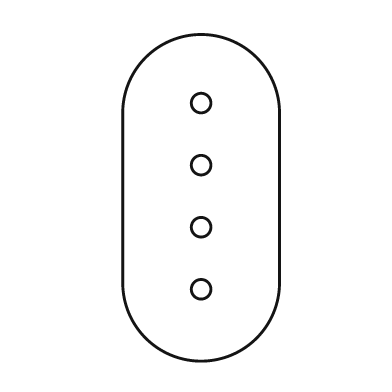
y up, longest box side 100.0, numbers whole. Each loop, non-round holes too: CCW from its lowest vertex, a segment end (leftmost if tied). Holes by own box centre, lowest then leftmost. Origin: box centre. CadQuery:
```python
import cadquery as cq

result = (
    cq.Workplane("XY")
    .moveTo(-24.0, -26.0)
    .threePointArc((0.0, -50.0), (24.0, -26.0))
    .lineTo(24.0, 26.0)
    .threePointArc((0.0, 50.0), (-24.0, 26.0))
    .close()
    .moveTo(0.0, -28.0)
    .circle(3.0)
    .moveTo(0.0, -9.0)
    .circle(3.0)
    .moveTo(0.0, 10.0)
    .circle(3.0)
    .moveTo(0.0, 29.0)
    .circle(3.0)
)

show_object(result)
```